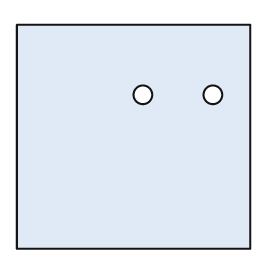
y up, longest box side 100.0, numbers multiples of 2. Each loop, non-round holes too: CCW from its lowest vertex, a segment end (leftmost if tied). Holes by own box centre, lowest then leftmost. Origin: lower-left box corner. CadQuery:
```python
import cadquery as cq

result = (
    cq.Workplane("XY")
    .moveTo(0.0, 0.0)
    .lineTo(100.0, 0.0)
    .lineTo(100.0, 96.0)
    .lineTo(0.0, 96.0)
    .close()
    .moveTo(54.0, 66.0)
    .circle(4.0)
    .moveTo(84.0, 66.0)
    .circle(4.0)
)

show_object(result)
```